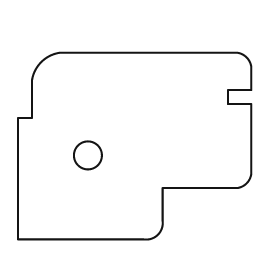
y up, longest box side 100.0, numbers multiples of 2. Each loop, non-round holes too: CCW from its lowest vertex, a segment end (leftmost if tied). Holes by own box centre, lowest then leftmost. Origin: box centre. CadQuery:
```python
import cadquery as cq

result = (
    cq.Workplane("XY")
    .moveTo(-50.0, -40.0)
    .lineTo(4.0, -40.0)
    .threePointArc((10.0, -38.0), (12.0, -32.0))
    .lineTo(12.0, -18.0)
    .lineTo(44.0, -18.0)
    .threePointArc((48.0, -16.0), (50.0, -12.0))
    .lineTo(50.0, 18.0)
    .lineTo(40.0, 18.0)
    .lineTo(40.0, 24.0)
    .lineTo(50.0, 24.0)
    .lineTo(50.0, 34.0)
    .threePointArc((48.0, 38.0), (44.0, 40.0))
    .lineTo(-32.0, 40.0)
    .threePointArc((-40.0, 36.0), (-44.0, 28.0))
    .lineTo(-44.0, 12.0)
    .lineTo(-50.0, 12.0)
    .close()
    .moveTo(-20.0, -4.0)
    .circle(6.0)
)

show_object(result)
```